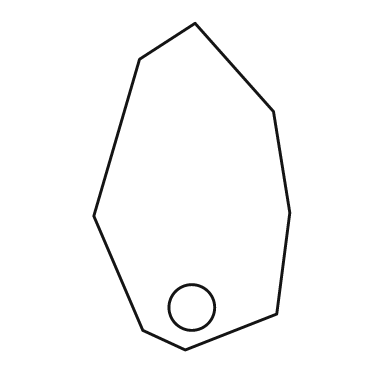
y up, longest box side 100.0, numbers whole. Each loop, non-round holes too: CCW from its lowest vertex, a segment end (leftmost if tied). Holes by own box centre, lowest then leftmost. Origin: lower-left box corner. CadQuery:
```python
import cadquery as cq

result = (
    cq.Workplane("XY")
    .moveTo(28.0, 0.0)
    .lineTo(56.0, 11.0)
    .lineTo(60.0, 42.0)
    .lineTo(55.0, 73.0)
    .lineTo(31.0, 100.0)
    .lineTo(14.0, 89.0)
    .lineTo(0.0, 41.0)
    .lineTo(15.0, 6.0)
    .close()
    .moveTo(30.0, 13.0)
    .circle(7.0)
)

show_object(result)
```